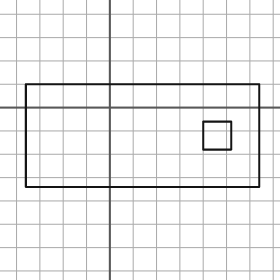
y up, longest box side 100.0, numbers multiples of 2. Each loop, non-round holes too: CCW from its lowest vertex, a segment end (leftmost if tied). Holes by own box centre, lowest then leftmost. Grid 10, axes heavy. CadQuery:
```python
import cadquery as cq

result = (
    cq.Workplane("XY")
    .moveTo(-36.0, -34.0)
    .lineTo(64.0, -34.0)
    .lineTo(64.0, 10.0)
    .lineTo(-36.0, 10.0)
    .close()
    .moveTo(40.0, -18.0)
    .lineTo(52.0, -18.0)
    .lineTo(52.0, -6.0)
    .lineTo(40.0, -6.0)
    .close()
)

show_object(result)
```